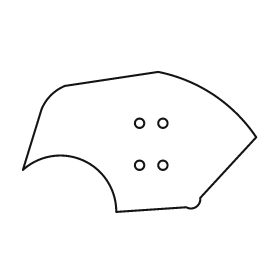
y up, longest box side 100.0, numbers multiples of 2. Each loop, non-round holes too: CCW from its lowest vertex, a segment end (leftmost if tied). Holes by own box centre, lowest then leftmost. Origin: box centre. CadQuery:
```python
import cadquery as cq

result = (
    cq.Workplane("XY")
    .moveTo(-10.0, -30.0)
    .lineTo(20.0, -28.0)
    .threePointArc((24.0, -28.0), (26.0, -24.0))
    .lineTo(50.0, 2.0)
    .threePointArc((32.0, 20.0), (8.0, 30.0))
    .lineTo(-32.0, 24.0)
    .threePointArc((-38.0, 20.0), (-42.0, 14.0))
    .lineTo(-50.0, -12.0)
    .threePointArc((-24.0, -8.0), (-10.0, -30.0))
    .close()
    .moveTo(0.0, -10.0)
    .circle(2.0)
    .moveTo(10.0, -10.0)
    .circle(2.0)
    .moveTo(0.0, 8.0)
    .circle(2.0)
    .moveTo(10.0, 8.0)
    .circle(2.0)
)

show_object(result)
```